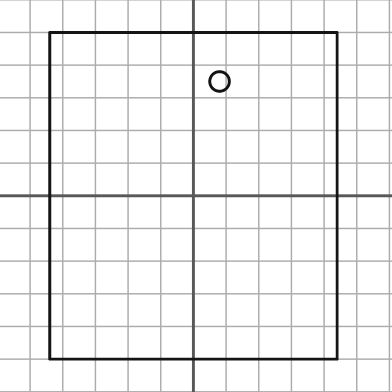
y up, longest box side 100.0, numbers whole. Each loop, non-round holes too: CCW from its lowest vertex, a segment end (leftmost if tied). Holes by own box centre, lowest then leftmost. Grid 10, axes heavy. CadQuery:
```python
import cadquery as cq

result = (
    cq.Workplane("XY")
    .moveTo(-44.0, -50.0)
    .lineTo(44.0, -50.0)
    .lineTo(44.0, 50.0)
    .lineTo(-44.0, 50.0)
    .close()
    .moveTo(8.0, 35.0)
    .circle(3.0)
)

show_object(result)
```